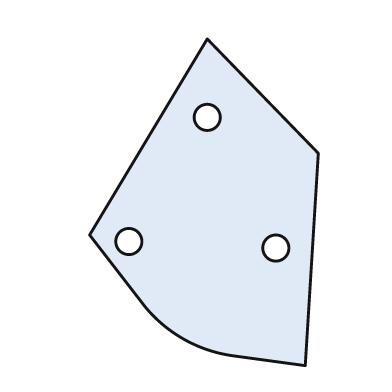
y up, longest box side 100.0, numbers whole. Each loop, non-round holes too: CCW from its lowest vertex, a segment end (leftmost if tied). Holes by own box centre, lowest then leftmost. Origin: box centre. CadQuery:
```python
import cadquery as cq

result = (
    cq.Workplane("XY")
    .moveTo(31.0, -50.0)
    .lineTo(35.0, 15.0)
    .lineTo(1.0, 50.0)
    .lineTo(-35.0, -10.0)
    .lineTo(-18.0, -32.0)
    .threePointArc((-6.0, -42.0), (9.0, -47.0))
    .close()
    .moveTo(22.0, -14.0)
    .circle(4.0)
    .moveTo(-23.0, -12.0)
    .circle(4.0)
    .moveTo(1.0, 26.0)
    .circle(4.0)
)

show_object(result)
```